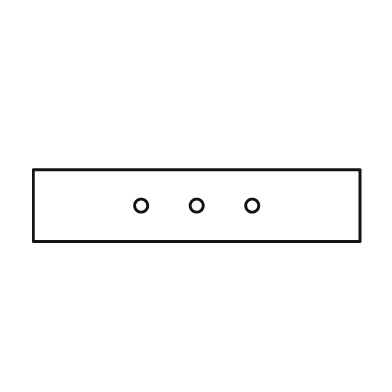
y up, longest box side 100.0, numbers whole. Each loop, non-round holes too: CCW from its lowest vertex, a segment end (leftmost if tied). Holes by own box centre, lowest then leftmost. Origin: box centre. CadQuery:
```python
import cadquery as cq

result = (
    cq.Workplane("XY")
    .moveTo(-50.0, -11.0)
    .lineTo(50.0, -11.0)
    .lineTo(50.0, 11.0)
    .lineTo(-50.0, 11.0)
    .close()
    .moveTo(-17.0, 0.0)
    .circle(2.0)
    .moveTo(0.0, 0.0)
    .circle(2.0)
    .moveTo(17.0, 0.0)
    .circle(2.0)
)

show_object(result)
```